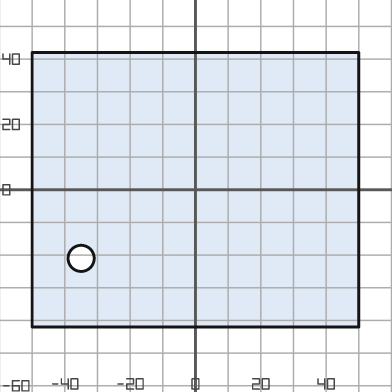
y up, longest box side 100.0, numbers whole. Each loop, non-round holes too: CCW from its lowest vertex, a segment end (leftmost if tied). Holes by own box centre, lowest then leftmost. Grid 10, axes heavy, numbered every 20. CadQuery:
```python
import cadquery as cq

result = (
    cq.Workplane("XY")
    .moveTo(-50.0, -42.0)
    .lineTo(50.0, -42.0)
    .lineTo(50.0, 42.0)
    .lineTo(-50.0, 42.0)
    .close()
    .moveTo(-35.0, -21.0)
    .circle(4.0)
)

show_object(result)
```